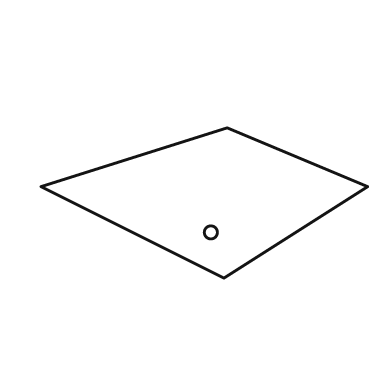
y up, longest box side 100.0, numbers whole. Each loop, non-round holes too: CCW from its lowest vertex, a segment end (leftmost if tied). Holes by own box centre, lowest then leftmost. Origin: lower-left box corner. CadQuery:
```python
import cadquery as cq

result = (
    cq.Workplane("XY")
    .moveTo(56.0, 0.0)
    .lineTo(100.0, 28.0)
    .lineTo(57.0, 46.0)
    .lineTo(0.0, 28.0)
    .close()
    .moveTo(52.0, 14.0)
    .circle(2.0)
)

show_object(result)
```